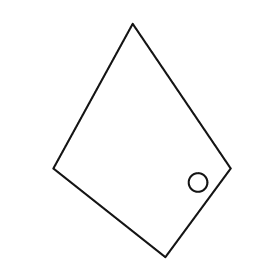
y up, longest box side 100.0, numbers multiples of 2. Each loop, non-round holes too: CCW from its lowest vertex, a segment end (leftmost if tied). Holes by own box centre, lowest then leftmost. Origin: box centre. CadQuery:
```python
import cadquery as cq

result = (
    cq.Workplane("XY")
    .moveTo(10.0, -50.0)
    .lineTo(38.0, -12.0)
    .lineTo(-4.0, 50.0)
    .lineTo(-38.0, -12.0)
    .close()
    .moveTo(24.0, -18.0)
    .circle(4.0)
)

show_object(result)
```